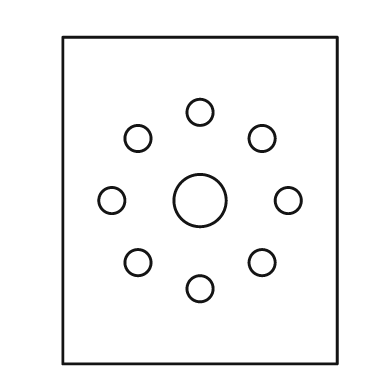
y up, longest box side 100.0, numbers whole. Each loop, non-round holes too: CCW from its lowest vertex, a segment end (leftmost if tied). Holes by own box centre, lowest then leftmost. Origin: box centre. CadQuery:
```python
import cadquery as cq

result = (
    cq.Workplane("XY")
    .moveTo(-42.0, -50.0)
    .lineTo(42.0, -50.0)
    .lineTo(42.0, 50.0)
    .lineTo(-42.0, 50.0)
    .close()
    .moveTo(0.0, -27.0)
    .circle(4.0)
    .moveTo(-19.0, -19.0)
    .circle(4.0)
    .moveTo(19.0, -19.0)
    .circle(4.0)
    .moveTo(-27.0, 0.0)
    .circle(4.0)
    .moveTo(0.0, 0.0)
    .circle(8.0)
    .moveTo(27.0, 0.0)
    .circle(4.0)
    .moveTo(-19.0, 19.0)
    .circle(4.0)
    .moveTo(19.0, 19.0)
    .circle(4.0)
    .moveTo(0.0, 27.0)
    .circle(4.0)
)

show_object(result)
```